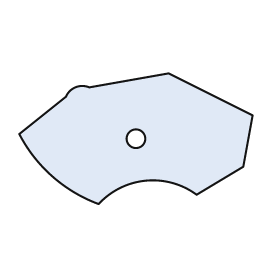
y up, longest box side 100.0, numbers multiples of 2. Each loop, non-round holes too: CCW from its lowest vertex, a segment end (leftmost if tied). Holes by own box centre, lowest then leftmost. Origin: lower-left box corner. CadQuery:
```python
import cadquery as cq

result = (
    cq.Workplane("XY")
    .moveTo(34.0, 0.0)
    .threePointArc((54.0, 10.0), (76.0, 4.0))
    .lineTo(96.0, 16.0)
    .lineTo(100.0, 38.0)
    .lineTo(64.0, 56.0)
    .lineTo(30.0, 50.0)
    .threePointArc((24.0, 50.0), (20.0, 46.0))
    .lineTo(0.0, 30.0)
    .threePointArc((14.0, 12.0), (34.0, 0.0))
    .close()
    .moveTo(50.0, 28.0)
    .circle(4.0)
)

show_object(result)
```